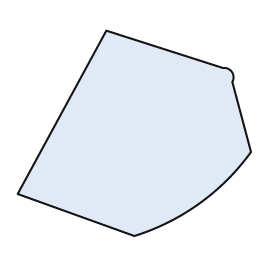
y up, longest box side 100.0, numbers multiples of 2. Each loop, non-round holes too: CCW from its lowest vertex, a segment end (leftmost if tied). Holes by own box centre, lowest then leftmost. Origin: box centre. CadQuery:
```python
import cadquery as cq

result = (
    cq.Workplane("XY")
    .moveTo(0.0, -44.0)
    .threePointArc((28.0, -30.0), (50.0, -8.0))
    .lineTo(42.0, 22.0)
    .threePointArc((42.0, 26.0), (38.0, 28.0))
    .lineTo(-12.0, 44.0)
    .lineTo(-50.0, -26.0)
    .close()
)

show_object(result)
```